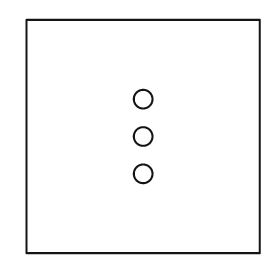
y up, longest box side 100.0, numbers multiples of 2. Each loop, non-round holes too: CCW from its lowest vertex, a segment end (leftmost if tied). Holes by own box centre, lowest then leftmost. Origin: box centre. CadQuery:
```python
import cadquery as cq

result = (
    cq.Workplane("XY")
    .moveTo(-50.0, -50.0)
    .lineTo(50.0, -50.0)
    .lineTo(50.0, 50.0)
    .lineTo(-50.0, 50.0)
    .close()
    .moveTo(0.0, -16.0)
    .circle(4.0)
    .moveTo(0.0, 0.0)
    .circle(4.0)
    .moveTo(0.0, 16.0)
    .circle(4.0)
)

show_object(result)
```